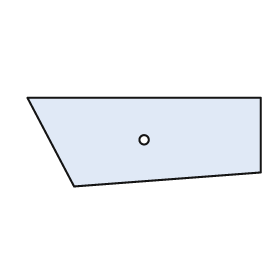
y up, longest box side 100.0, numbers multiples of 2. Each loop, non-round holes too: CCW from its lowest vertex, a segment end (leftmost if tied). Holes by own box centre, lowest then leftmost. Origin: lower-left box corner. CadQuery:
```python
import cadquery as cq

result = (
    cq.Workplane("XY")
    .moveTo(20.0, 0.0)
    .lineTo(100.0, 6.0)
    .lineTo(100.0, 38.0)
    .lineTo(0.0, 38.0)
    .close()
    .moveTo(50.0, 20.0)
    .circle(2.0)
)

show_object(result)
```